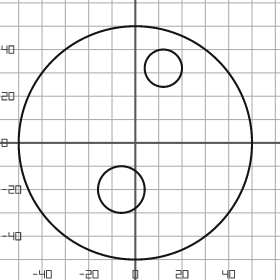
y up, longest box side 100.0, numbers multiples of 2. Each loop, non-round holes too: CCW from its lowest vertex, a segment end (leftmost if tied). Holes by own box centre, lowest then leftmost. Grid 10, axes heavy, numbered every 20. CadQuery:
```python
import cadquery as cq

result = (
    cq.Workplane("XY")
    .moveTo(0.0, 0.0)
    .circle(50.0)
    .moveTo(-6.0, -20.0)
    .circle(10.0)
    .moveTo(12.0, 32.0)
    .circle(8.0)
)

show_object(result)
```